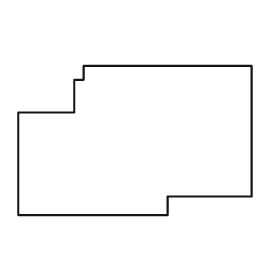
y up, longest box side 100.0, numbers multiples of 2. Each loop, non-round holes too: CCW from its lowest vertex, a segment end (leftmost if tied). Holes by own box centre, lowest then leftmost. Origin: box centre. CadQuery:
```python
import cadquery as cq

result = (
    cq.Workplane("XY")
    .moveTo(-50.0, -32.0)
    .lineTo(14.0, -32.0)
    .lineTo(14.0, -24.0)
    .lineTo(50.0, -24.0)
    .lineTo(50.0, 32.0)
    .lineTo(-22.0, 32.0)
    .lineTo(-22.0, 26.0)
    .lineTo(-26.0, 26.0)
    .lineTo(-26.0, 12.0)
    .lineTo(-50.0, 12.0)
    .close()
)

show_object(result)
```